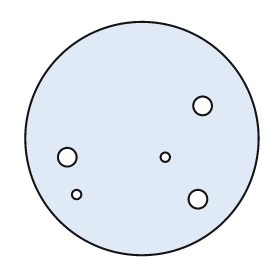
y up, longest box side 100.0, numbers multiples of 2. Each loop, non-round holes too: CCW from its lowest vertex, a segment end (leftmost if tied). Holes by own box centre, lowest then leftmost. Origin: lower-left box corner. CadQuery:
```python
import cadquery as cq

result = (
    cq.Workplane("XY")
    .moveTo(50.0, 50.0)
    .circle(50.0)
    .moveTo(74.0, 24.0)
    .circle(4.0)
    .moveTo(22.0, 26.0)
    .circle(2.0)
    .moveTo(18.0, 42.0)
    .circle(4.0)
    .moveTo(60.0, 42.0)
    .circle(2.0)
    .moveTo(76.0, 64.0)
    .circle(4.0)
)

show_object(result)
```